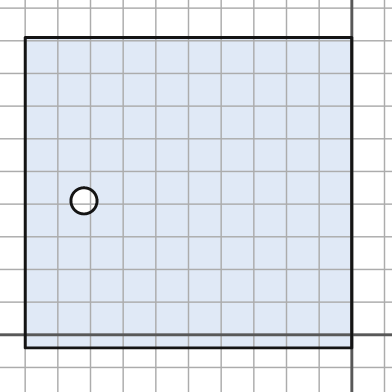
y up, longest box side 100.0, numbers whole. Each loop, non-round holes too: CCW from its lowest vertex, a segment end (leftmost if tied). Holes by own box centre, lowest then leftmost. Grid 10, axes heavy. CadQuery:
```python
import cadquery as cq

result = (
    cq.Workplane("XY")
    .moveTo(-100.0, -4.0)
    .lineTo(0.0, -4.0)
    .lineTo(0.0, 91.0)
    .lineTo(-100.0, 91.0)
    .close()
    .moveTo(-82.0, 41.0)
    .circle(4.0)
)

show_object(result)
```